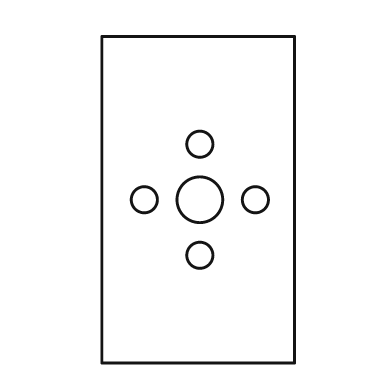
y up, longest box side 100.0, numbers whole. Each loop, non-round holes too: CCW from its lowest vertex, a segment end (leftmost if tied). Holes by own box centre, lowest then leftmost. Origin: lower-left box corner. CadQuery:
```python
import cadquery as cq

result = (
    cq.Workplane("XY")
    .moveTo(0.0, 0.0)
    .lineTo(59.0, 0.0)
    .lineTo(59.0, 100.0)
    .lineTo(0.0, 100.0)
    .close()
    .moveTo(30.0, 33.0)
    .circle(4.0)
    .moveTo(13.0, 50.0)
    .circle(4.0)
    .moveTo(30.0, 50.0)
    .circle(7.0)
    .moveTo(47.0, 50.0)
    .circle(4.0)
    .moveTo(30.0, 67.0)
    .circle(4.0)
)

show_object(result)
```